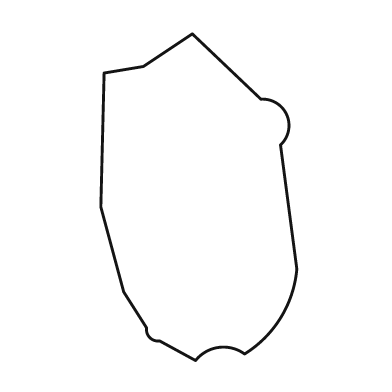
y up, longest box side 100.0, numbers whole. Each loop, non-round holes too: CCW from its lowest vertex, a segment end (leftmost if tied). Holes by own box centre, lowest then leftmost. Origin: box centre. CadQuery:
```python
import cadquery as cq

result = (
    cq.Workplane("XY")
    .moveTo(-1.0, -50.0)
    .threePointArc((6.0, -46.0), (14.0, -48.0))
    .threePointArc((25.0, -37.0), (30.0, -22.0))
    .lineTo(25.0, 16.0)
    .threePointArc((27.0, 25.0), (19.0, 30.0))
    .lineTo(-2.0, 50.0)
    .lineTo(-17.0, 40.0)
    .lineTo(-29.0, 38.0)
    .lineTo(-30.0, -3.0)
    .lineTo(-23.0, -29.0)
    .lineTo(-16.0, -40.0)
    .threePointArc((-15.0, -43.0), (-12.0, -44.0))
    .close()
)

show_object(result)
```